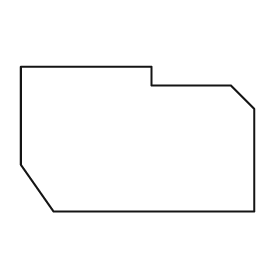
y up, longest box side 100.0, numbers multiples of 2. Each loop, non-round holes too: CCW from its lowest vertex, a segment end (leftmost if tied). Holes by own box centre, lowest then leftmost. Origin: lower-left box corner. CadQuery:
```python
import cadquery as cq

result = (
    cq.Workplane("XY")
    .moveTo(14.0, 0.0)
    .lineTo(100.0, 0.0)
    .lineTo(100.0, 44.0)
    .lineTo(90.0, 54.0)
    .lineTo(56.0, 54.0)
    .lineTo(56.0, 62.0)
    .lineTo(0.0, 62.0)
    .lineTo(0.0, 20.0)
    .close()
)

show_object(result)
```